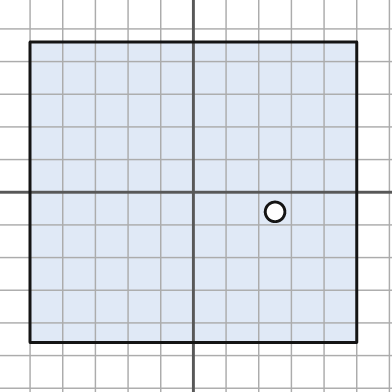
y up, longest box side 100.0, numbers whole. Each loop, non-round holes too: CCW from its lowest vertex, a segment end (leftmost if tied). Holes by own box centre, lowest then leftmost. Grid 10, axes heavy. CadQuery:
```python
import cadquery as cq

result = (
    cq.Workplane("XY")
    .moveTo(-50.0, -46.0)
    .lineTo(50.0, -46.0)
    .lineTo(50.0, 46.0)
    .lineTo(-50.0, 46.0)
    .close()
    .moveTo(25.0, -6.0)
    .circle(3.0)
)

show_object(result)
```